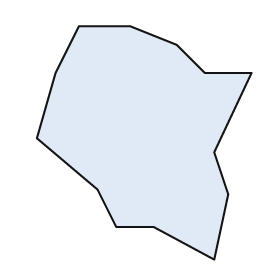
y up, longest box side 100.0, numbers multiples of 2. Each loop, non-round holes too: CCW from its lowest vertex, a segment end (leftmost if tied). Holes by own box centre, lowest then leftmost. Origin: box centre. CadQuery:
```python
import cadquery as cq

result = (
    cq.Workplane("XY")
    .moveTo(30.0, -50.0)
    .lineTo(36.0, -22.0)
    .lineTo(30.0, -4.0)
    .lineTo(46.0, 30.0)
    .lineTo(26.0, 30.0)
    .lineTo(14.0, 42.0)
    .lineTo(-6.0, 50.0)
    .lineTo(-28.0, 50.0)
    .lineTo(-38.0, 30.0)
    .lineTo(-46.0, 2.0)
    .lineTo(-20.0, -20.0)
    .lineTo(-12.0, -36.0)
    .lineTo(4.0, -36.0)
    .close()
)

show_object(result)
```